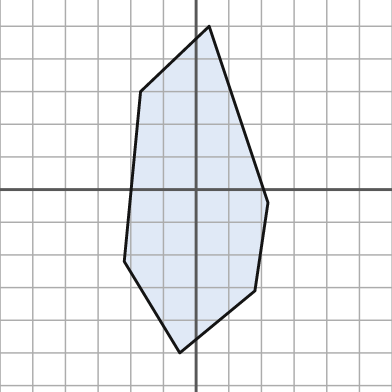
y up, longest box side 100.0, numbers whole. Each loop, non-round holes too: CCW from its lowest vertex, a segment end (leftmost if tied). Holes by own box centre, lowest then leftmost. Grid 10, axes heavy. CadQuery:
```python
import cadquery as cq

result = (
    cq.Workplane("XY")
    .moveTo(-5.0, -50.0)
    .lineTo(18.0, -31.0)
    .lineTo(22.0, -4.0)
    .lineTo(4.0, 50.0)
    .lineTo(-17.0, 30.0)
    .lineTo(-22.0, -22.0)
    .close()
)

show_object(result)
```